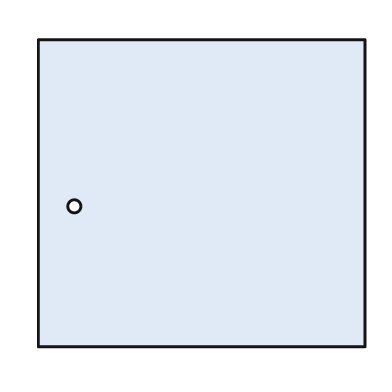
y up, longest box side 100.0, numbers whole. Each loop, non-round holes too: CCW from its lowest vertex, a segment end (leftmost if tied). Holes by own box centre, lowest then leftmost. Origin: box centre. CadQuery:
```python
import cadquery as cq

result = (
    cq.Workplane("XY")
    .moveTo(-50.0, -47.0)
    .lineTo(50.0, -47.0)
    .lineTo(50.0, 47.0)
    .lineTo(-50.0, 47.0)
    .close()
    .moveTo(-39.0, -4.0)
    .circle(2.0)
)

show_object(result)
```